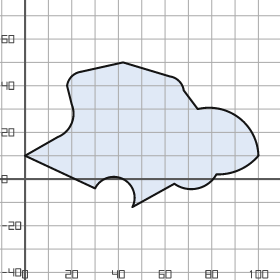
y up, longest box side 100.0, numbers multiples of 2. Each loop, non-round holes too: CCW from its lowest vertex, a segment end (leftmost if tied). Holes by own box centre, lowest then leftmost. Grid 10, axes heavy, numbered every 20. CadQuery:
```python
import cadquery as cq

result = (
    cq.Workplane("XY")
    .moveTo(46.0, -12.0)
    .lineTo(64.0, -2.0)
    .threePointArc((74.0, -4.0), (82.0, 2.0))
    .threePointArc((92.0, 4.0), (100.0, 10.0))
    .threePointArc((92.0, 26.0), (74.0, 30.0))
    .lineTo(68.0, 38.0)
    .threePointArc((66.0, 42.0), (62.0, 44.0))
    .lineTo(42.0, 50.0)
    .lineTo(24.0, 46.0)
    .threePointArc((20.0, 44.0), (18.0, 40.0))
    .lineTo(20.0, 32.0)
    .threePointArc((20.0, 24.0), (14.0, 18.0))
    .lineTo(0.0, 10.0)
    .lineTo(30.0, -4.0)
    .threePointArc((42.0, 0.0), (46.0, -12.0))
    .close()
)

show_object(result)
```